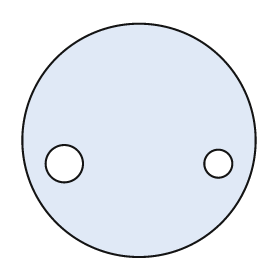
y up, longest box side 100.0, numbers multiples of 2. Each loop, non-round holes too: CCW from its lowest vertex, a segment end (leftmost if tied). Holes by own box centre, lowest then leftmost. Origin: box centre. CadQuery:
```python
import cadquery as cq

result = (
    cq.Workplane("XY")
    .moveTo(0.0, 0.0)
    .circle(50.0)
    .moveTo(-32.0, -10.0)
    .circle(8.0)
    .moveTo(34.0, -10.0)
    .circle(6.0)
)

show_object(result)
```